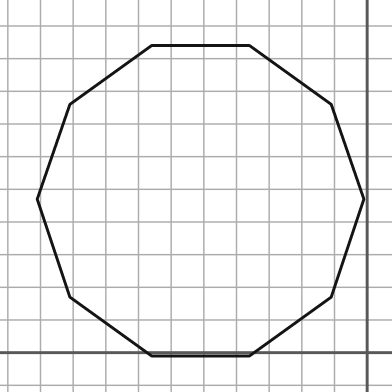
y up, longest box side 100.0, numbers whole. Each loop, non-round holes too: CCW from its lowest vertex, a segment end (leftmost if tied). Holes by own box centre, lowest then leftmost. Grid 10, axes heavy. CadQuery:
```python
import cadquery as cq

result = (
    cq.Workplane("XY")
    .moveTo(-66.0, -1.0)
    .lineTo(-36.0, -1.0)
    .lineTo(-11.0, 17.0)
    .lineTo(-1.0, 47.0)
    .lineTo(-11.0, 76.0)
    .lineTo(-36.0, 94.0)
    .lineTo(-66.0, 94.0)
    .lineTo(-91.0, 76.0)
    .lineTo(-101.0, 47.0)
    .lineTo(-91.0, 17.0)
    .close()
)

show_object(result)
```